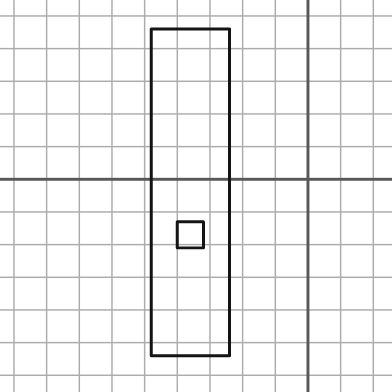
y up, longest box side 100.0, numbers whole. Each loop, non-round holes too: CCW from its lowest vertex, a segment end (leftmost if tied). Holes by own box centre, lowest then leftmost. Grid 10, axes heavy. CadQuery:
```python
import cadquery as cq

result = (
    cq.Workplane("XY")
    .moveTo(-48.0, -54.0)
    .lineTo(-24.0, -54.0)
    .lineTo(-24.0, 46.0)
    .lineTo(-48.0, 46.0)
    .close()
    .moveTo(-40.0, -21.0)
    .lineTo(-32.0, -21.0)
    .lineTo(-32.0, -13.0)
    .lineTo(-40.0, -13.0)
    .close()
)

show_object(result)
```